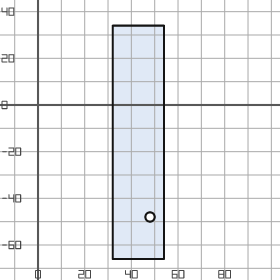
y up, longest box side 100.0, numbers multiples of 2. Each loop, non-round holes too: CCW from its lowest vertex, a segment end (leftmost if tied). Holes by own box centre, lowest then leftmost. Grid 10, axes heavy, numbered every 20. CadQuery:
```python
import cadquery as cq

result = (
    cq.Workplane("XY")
    .moveTo(32.0, -66.0)
    .lineTo(54.0, -66.0)
    .lineTo(54.0, 34.0)
    .lineTo(32.0, 34.0)
    .close()
    .moveTo(48.0, -48.0)
    .circle(2.0)
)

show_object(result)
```